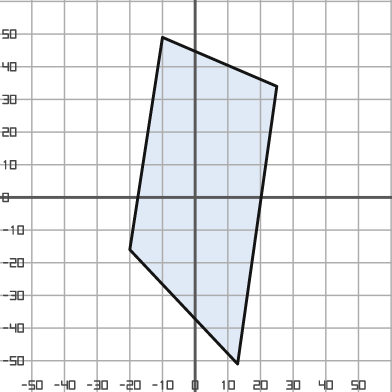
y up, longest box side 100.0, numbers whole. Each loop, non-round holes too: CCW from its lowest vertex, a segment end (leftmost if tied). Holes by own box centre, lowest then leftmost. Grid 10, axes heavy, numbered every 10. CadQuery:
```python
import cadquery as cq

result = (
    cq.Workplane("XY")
    .moveTo(13.0, -51.0)
    .lineTo(25.0, 34.0)
    .lineTo(-10.0, 49.0)
    .lineTo(-20.0, -16.0)
    .close()
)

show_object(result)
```